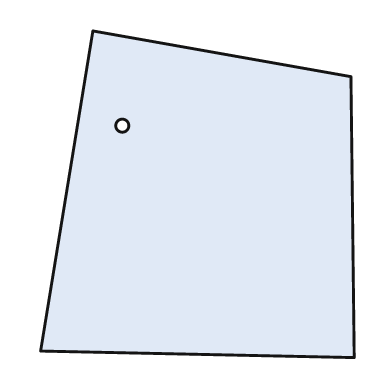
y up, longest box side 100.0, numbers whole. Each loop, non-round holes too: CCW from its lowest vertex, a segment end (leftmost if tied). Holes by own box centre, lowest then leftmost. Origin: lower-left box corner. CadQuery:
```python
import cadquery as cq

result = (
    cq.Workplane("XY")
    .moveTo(96.0, 0.0)
    .lineTo(95.0, 86.0)
    .lineTo(16.0, 100.0)
    .lineTo(0.0, 2.0)
    .close()
    .moveTo(25.0, 71.0)
    .circle(2.0)
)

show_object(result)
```